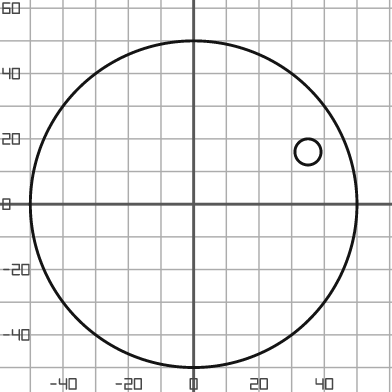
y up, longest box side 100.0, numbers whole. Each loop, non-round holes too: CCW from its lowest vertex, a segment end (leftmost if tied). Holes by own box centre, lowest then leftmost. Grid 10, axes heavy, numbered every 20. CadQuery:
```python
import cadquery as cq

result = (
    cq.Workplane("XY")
    .moveTo(0.0, 0.0)
    .circle(50.0)
    .moveTo(35.0, 16.0)
    .circle(4.0)
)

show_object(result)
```